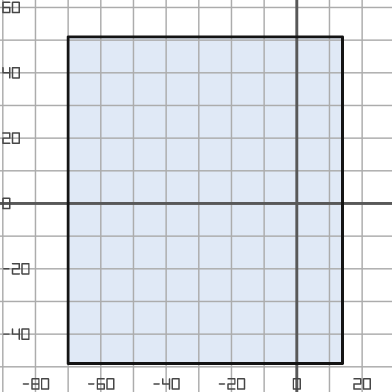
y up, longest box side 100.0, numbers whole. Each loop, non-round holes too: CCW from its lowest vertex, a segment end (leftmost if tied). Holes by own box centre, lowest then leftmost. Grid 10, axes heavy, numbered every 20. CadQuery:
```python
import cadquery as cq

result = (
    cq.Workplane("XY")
    .moveTo(-70.0, -49.0)
    .lineTo(14.0, -49.0)
    .lineTo(14.0, 51.0)
    .lineTo(-70.0, 51.0)
    .close()
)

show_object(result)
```